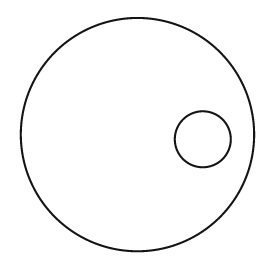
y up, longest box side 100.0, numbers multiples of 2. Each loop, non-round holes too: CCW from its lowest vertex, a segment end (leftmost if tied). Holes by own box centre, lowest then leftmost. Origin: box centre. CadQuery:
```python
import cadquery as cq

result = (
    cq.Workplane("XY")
    .moveTo(0.0, 0.0)
    .circle(50.0)
    .moveTo(28.0, -2.0)
    .circle(12.0)
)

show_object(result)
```